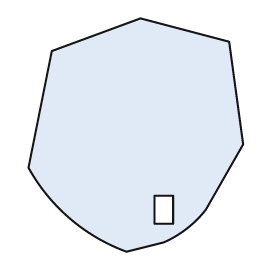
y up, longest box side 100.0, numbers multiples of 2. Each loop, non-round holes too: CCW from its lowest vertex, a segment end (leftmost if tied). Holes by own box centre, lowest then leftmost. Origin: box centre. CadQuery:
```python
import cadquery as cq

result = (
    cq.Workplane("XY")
    .moveTo(-4.0, -50.0)
    .lineTo(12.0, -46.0)
    .threePointArc((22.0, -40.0), (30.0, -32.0))
    .lineTo(46.0, -4.0)
    .lineTo(40.0, 40.0)
    .lineTo(2.0, 50.0)
    .lineTo(-36.0, 36.0)
    .lineTo(-46.0, -14.0)
    .threePointArc((-28.0, -36.0), (-4.0, -50.0))
    .close()
    .moveTo(8.0, -38.0)
    .lineTo(16.0, -38.0)
    .lineTo(16.0, -26.0)
    .lineTo(8.0, -26.0)
    .close()
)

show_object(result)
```